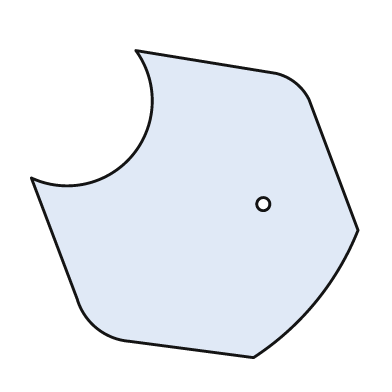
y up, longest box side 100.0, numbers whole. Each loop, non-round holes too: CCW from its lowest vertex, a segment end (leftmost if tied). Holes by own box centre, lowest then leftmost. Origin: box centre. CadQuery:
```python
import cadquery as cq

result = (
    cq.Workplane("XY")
    .moveTo(18.0, -47.0)
    .threePointArc((37.0, -30.0), (50.0, -8.0))
    .lineTo(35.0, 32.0)
    .threePointArc((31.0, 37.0), (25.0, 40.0))
    .lineTo(-18.0, 47.0)
    .threePointArc((-19.0, 15.0), (-50.0, 8.0))
    .lineTo(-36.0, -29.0)
    .threePointArc((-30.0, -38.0), (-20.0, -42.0))
    .close()
    .moveTo(21.0, 0.0)
    .circle(2.0)
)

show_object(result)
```